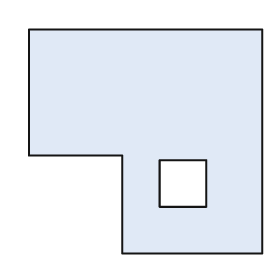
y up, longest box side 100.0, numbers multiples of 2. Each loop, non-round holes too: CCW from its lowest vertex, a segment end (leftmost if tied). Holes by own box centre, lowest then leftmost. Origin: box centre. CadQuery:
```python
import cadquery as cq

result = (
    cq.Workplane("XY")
    .moveTo(-10.0, -48.0)
    .lineTo(50.0, -48.0)
    .lineTo(50.0, 48.0)
    .lineTo(-50.0, 48.0)
    .lineTo(-50.0, -6.0)
    .lineTo(-10.0, -6.0)
    .close()
    .moveTo(6.0, -28.0)
    .lineTo(26.0, -28.0)
    .lineTo(26.0, -8.0)
    .lineTo(6.0, -8.0)
    .close()
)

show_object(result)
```